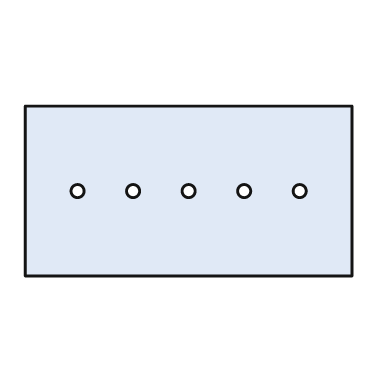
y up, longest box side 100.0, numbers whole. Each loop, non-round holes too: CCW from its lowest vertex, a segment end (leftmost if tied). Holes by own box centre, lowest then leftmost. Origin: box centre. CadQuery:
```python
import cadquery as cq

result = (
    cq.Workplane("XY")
    .moveTo(-50.0, -26.0)
    .lineTo(50.0, -26.0)
    .lineTo(50.0, 26.0)
    .lineTo(-50.0, 26.0)
    .close()
    .moveTo(-34.0, 0.0)
    .circle(2.0)
    .moveTo(-17.0, 0.0)
    .circle(2.0)
    .moveTo(0.0, 0.0)
    .circle(2.0)
    .moveTo(17.0, 0.0)
    .circle(2.0)
    .moveTo(34.0, 0.0)
    .circle(2.0)
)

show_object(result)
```